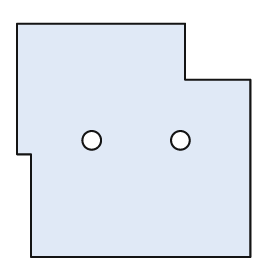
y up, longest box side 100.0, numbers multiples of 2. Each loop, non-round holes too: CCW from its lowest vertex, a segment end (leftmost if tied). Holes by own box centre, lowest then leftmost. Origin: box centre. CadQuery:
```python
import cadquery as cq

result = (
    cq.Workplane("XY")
    .moveTo(-44.0, -50.0)
    .lineTo(50.0, -50.0)
    .lineTo(50.0, 26.0)
    .lineTo(22.0, 26.0)
    .lineTo(22.0, 50.0)
    .lineTo(-50.0, 50.0)
    .lineTo(-50.0, -6.0)
    .lineTo(-44.0, -6.0)
    .close()
    .moveTo(-18.0, 0.0)
    .circle(4.0)
    .moveTo(20.0, 0.0)
    .circle(4.0)
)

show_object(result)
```